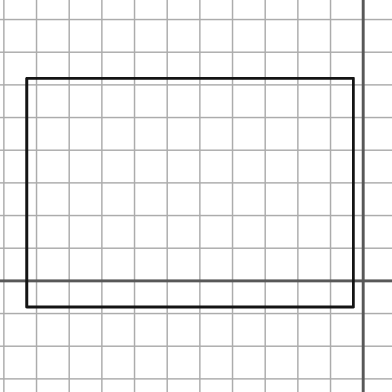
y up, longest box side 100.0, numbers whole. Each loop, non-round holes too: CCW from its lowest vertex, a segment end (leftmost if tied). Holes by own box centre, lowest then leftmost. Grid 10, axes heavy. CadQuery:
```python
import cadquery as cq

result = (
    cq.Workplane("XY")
    .moveTo(-103.0, -8.0)
    .lineTo(-3.0, -8.0)
    .lineTo(-3.0, 62.0)
    .lineTo(-103.0, 62.0)
    .close()
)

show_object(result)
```